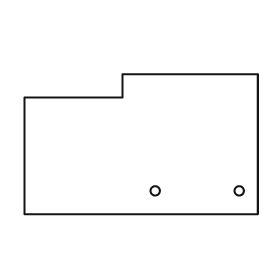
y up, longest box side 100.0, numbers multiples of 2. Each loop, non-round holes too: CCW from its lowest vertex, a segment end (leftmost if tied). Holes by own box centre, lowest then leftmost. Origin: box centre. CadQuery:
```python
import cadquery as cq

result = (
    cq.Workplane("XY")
    .moveTo(-50.0, -30.0)
    .lineTo(50.0, -30.0)
    .lineTo(50.0, 30.0)
    .lineTo(-8.0, 30.0)
    .lineTo(-8.0, 20.0)
    .lineTo(-50.0, 20.0)
    .close()
    .moveTo(6.0, -20.0)
    .circle(2.0)
    .moveTo(42.0, -20.0)
    .circle(2.0)
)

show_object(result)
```